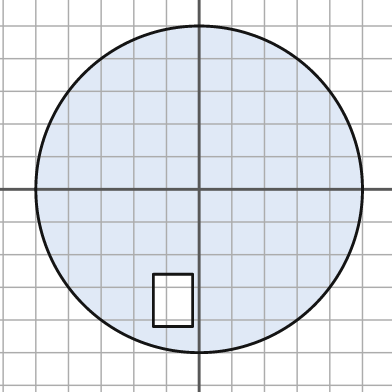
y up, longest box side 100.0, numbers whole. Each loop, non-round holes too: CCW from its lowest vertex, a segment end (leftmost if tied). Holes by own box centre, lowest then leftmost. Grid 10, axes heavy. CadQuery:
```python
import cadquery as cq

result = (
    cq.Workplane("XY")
    .moveTo(0.0, 0.0)
    .circle(50.0)
    .moveTo(-14.0, -42.0)
    .lineTo(-2.0, -42.0)
    .lineTo(-2.0, -26.0)
    .lineTo(-14.0, -26.0)
    .close()
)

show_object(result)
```